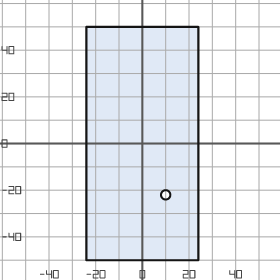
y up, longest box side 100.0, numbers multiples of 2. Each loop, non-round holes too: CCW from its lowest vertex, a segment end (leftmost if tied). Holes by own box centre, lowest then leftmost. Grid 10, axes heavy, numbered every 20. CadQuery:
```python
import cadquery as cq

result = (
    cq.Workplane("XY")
    .moveTo(-24.0, -50.0)
    .lineTo(24.0, -50.0)
    .lineTo(24.0, 50.0)
    .lineTo(-24.0, 50.0)
    .close()
    .moveTo(10.0, -22.0)
    .circle(2.0)
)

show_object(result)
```